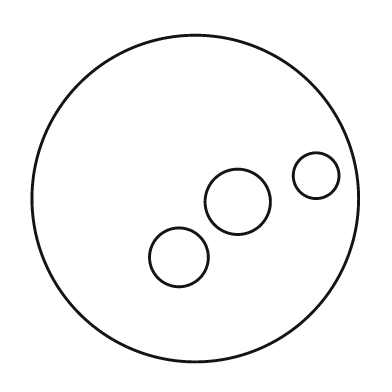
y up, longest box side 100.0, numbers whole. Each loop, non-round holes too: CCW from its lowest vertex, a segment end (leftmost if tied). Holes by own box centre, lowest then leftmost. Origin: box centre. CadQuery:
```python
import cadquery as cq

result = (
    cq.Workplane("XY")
    .moveTo(0.0, 0.0)
    .circle(50.0)
    .moveTo(-5.0, -18.0)
    .circle(9.0)
    .moveTo(13.0, -1.0)
    .circle(10.0)
    .moveTo(37.0, 7.0)
    .circle(7.0)
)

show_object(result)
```